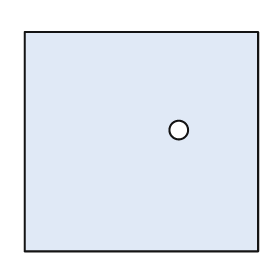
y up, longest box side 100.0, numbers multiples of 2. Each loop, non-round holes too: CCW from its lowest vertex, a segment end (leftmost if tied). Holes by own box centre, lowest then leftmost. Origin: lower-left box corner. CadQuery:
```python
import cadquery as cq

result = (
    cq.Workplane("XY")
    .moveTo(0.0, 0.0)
    .lineTo(100.0, 0.0)
    .lineTo(100.0, 94.0)
    .lineTo(0.0, 94.0)
    .close()
    .moveTo(66.0, 52.0)
    .circle(4.0)
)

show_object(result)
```